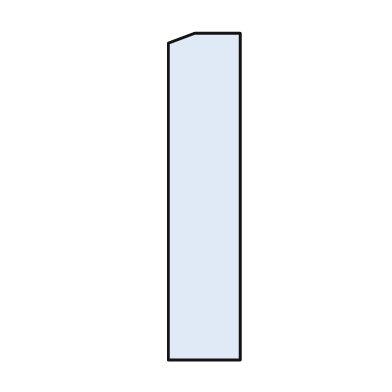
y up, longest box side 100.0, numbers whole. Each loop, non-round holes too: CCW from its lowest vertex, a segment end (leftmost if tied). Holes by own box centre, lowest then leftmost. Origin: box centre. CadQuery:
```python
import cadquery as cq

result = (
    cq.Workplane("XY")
    .moveTo(-11.0, -50.0)
    .lineTo(11.0, -50.0)
    .lineTo(11.0, 50.0)
    .lineTo(-3.0, 50.0)
    .lineTo(-11.0, 47.0)
    .close()
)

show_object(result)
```